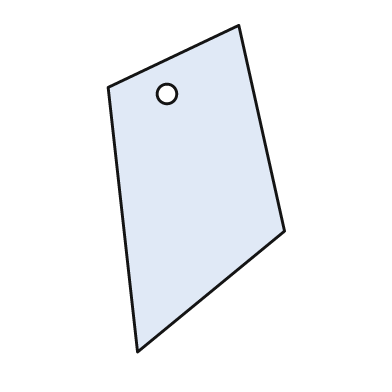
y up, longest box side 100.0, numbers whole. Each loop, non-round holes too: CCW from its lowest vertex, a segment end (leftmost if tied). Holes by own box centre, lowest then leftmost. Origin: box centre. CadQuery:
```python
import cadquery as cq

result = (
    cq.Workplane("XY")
    .moveTo(-18.0, -50.0)
    .lineTo(27.0, -13.0)
    .lineTo(13.0, 50.0)
    .lineTo(-27.0, 31.0)
    .close()
    .moveTo(-9.0, 29.0)
    .circle(3.0)
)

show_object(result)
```